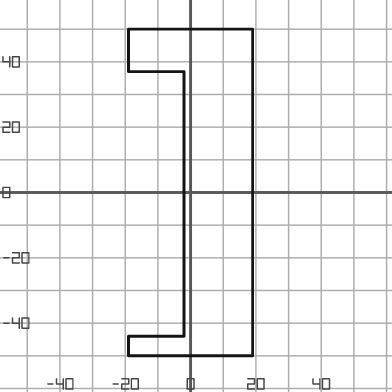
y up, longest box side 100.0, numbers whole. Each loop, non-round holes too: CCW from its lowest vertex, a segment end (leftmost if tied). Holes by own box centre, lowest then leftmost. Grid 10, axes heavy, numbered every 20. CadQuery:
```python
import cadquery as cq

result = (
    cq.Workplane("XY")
    .moveTo(-19.0, -50.0)
    .lineTo(19.0, -50.0)
    .lineTo(19.0, 50.0)
    .lineTo(-19.0, 50.0)
    .lineTo(-19.0, 37.0)
    .lineTo(-2.0, 37.0)
    .lineTo(-2.0, -44.0)
    .lineTo(-19.0, -44.0)
    .close()
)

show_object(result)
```